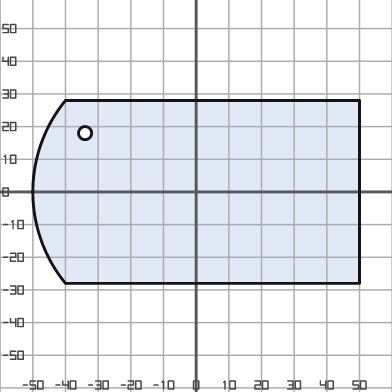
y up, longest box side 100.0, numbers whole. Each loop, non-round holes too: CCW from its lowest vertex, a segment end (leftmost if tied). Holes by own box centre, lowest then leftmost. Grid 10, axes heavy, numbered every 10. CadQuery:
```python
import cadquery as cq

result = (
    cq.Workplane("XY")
    .moveTo(-40.0, -28.0)
    .lineTo(50.0, -28.0)
    .lineTo(50.0, 28.0)
    .lineTo(-40.0, 28.0)
    .threePointArc((-50.0, 0.0), (-40.0, -28.0))
    .close()
    .moveTo(-34.0, 18.0)
    .circle(2.0)
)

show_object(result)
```